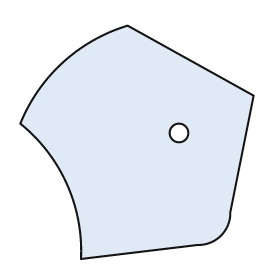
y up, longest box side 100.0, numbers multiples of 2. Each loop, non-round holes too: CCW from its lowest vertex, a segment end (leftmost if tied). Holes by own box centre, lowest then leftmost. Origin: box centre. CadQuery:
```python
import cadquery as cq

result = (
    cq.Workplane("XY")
    .moveTo(-24.0, -50.0)
    .lineTo(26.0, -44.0)
    .threePointArc((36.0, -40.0), (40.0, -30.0))
    .lineTo(50.0, 20.0)
    .lineTo(-4.0, 50.0)
    .threePointArc((-32.0, 34.0), (-50.0, 8.0))
    .threePointArc((-30.0, -18.0), (-24.0, -50.0))
    .close()
    .moveTo(18.0, 4.0)
    .circle(4.0)
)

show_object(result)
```